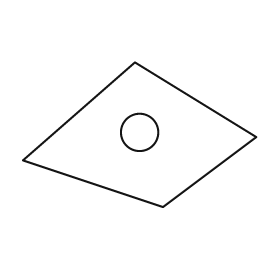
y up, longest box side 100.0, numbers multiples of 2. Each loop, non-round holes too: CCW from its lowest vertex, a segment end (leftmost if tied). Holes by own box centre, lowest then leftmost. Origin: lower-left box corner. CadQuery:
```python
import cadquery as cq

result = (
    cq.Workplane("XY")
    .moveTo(60.0, 0.0)
    .lineTo(100.0, 30.0)
    .lineTo(48.0, 62.0)
    .lineTo(0.0, 20.0)
    .close()
    .moveTo(50.0, 32.0)
    .circle(8.0)
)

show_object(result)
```